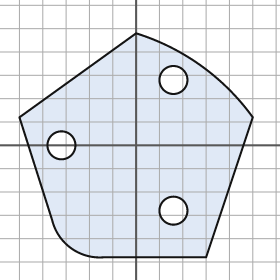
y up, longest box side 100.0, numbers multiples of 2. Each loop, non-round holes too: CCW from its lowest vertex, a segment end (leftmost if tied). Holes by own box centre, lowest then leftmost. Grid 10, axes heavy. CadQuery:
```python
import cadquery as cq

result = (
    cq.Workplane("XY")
    .moveTo(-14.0, -48.0)
    .lineTo(30.0, -48.0)
    .lineTo(50.0, 12.0)
    .threePointArc((28.0, 34.0), (0.0, 48.0))
    .lineTo(-50.0, 12.0)
    .lineTo(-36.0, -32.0)
    .threePointArc((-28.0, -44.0), (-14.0, -48.0))
    .close()
    .moveTo(16.0, -28.0)
    .circle(6.0)
    .moveTo(-32.0, 0.0)
    .circle(6.0)
    .moveTo(16.0, 28.0)
    .circle(6.0)
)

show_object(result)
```